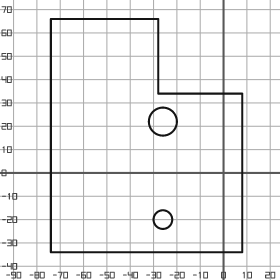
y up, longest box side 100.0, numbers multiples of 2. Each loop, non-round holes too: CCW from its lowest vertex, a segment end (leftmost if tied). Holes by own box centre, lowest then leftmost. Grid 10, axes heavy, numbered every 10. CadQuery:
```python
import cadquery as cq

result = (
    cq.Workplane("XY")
    .moveTo(-74.0, -34.0)
    .lineTo(8.0, -34.0)
    .lineTo(8.0, 34.0)
    .lineTo(-28.0, 34.0)
    .lineTo(-28.0, 66.0)
    .lineTo(-74.0, 66.0)
    .close()
    .moveTo(-26.0, -20.0)
    .circle(4.0)
    .moveTo(-26.0, 22.0)
    .circle(6.0)
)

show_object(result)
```